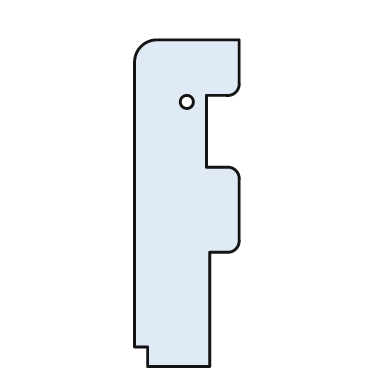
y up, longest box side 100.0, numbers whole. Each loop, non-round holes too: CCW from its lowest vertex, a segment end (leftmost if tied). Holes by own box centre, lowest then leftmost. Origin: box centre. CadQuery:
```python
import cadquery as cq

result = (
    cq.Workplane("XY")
    .moveTo(-12.0, -50.0)
    .lineTo(7.0, -50.0)
    .lineTo(7.0, -15.0)
    .lineTo(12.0, -15.0)
    .threePointArc((15.0, -14.0), (16.0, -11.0))
    .lineTo(16.0, 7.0)
    .threePointArc((15.0, 10.0), (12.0, 11.0))
    .lineTo(6.0, 11.0)
    .lineTo(6.0, 33.0)
    .lineTo(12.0, 33.0)
    .threePointArc((15.0, 34.0), (16.0, 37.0))
    .lineTo(16.0, 50.0)
    .lineTo(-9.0, 50.0)
    .threePointArc((-14.0, 48.0), (-16.0, 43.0))
    .lineTo(-16.0, -44.0)
    .lineTo(-12.0, -44.0)
    .close()
    .moveTo(0.0, 31.0)
    .circle(2.0)
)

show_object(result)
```